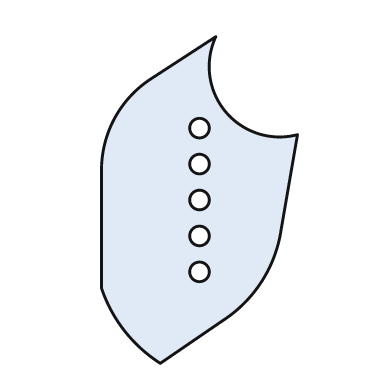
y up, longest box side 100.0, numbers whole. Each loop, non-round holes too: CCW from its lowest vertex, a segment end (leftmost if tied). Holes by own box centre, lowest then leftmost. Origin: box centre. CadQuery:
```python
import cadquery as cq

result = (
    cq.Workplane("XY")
    .moveTo(-12.0, -50.0)
    .lineTo(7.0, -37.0)
    .threePointArc((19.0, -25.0), (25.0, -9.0))
    .lineTo(30.0, 20.0)
    .threePointArc((8.0, 27.0), (5.0, 50.0))
    .lineTo(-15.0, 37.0)
    .threePointArc((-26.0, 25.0), (-30.0, 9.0))
    .lineTo(-30.0, -27.0)
    .threePointArc((-23.0, -40.0), (-12.0, -50.0))
    .close()
    .moveTo(0.0, -22.0)
    .circle(3.0)
    .moveTo(0.0, -11.0)
    .circle(3.0)
    .moveTo(0.0, 0.0)
    .circle(3.0)
    .moveTo(0.0, 11.0)
    .circle(3.0)
    .moveTo(0.0, 22.0)
    .circle(3.0)
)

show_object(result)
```